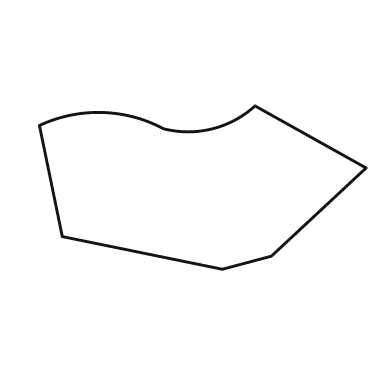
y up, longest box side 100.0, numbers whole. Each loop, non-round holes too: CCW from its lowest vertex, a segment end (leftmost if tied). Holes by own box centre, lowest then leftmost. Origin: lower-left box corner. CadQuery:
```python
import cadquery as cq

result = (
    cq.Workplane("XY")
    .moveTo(56.0, 0.0)
    .lineTo(71.0, 4.0)
    .lineTo(100.0, 31.0)
    .lineTo(66.0, 50.0)
    .threePointArc((53.0, 43.0), (38.0, 43.0))
    .threePointArc((19.0, 48.0), (0.0, 44.0))
    .lineTo(7.0, 10.0)
    .close()
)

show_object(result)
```